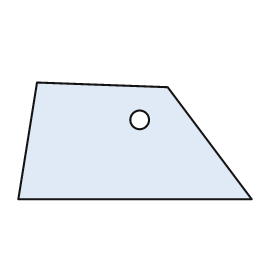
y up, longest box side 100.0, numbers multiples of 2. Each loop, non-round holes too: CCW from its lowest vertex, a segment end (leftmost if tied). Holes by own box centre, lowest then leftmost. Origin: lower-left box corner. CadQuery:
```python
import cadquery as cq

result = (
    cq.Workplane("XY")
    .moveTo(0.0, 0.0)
    .lineTo(100.0, 0.0)
    .lineTo(64.0, 48.0)
    .lineTo(8.0, 50.0)
    .close()
    .moveTo(52.0, 34.0)
    .circle(4.0)
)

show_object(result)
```